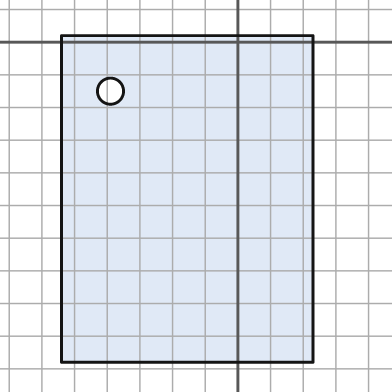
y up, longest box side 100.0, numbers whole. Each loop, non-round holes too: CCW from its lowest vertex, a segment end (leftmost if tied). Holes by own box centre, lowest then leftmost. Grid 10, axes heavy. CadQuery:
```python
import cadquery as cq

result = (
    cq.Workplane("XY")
    .moveTo(-54.0, -98.0)
    .lineTo(23.0, -98.0)
    .lineTo(23.0, 2.0)
    .lineTo(-54.0, 2.0)
    .close()
    .moveTo(-39.0, -15.0)
    .circle(4.0)
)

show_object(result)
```